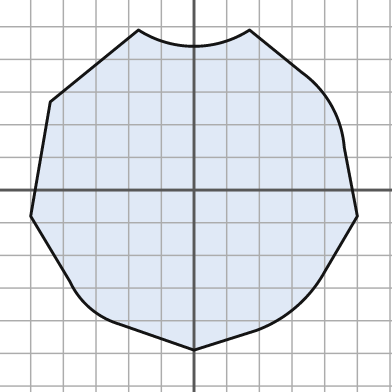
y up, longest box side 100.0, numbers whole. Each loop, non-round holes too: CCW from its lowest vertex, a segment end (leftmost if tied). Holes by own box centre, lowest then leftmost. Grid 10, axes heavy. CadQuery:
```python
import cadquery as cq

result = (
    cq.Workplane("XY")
    .moveTo(0.0, -49.0)
    .lineTo(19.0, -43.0)
    .threePointArc((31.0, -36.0), (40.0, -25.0))
    .lineTo(50.0, -8.0)
    .lineTo(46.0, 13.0)
    .threePointArc((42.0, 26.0), (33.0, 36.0))
    .lineTo(17.0, 49.0)
    .threePointArc((0.0, 44.0), (-17.0, 49.0))
    .lineTo(-44.0, 27.0)
    .lineTo(-50.0, -8.0)
    .lineTo(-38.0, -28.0)
    .threePointArc((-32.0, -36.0), (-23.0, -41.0))
    .close()
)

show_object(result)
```